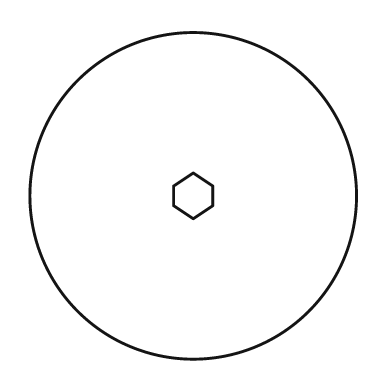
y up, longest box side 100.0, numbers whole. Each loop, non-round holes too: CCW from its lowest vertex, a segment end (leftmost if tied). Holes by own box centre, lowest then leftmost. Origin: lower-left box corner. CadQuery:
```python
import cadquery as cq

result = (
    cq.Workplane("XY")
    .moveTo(50.0, 50.0)
    .circle(50.0)
    .moveTo(50.0, 43.0)
    .lineTo(56.0, 47.0)
    .lineTo(56.0, 53.0)
    .lineTo(50.0, 57.0)
    .lineTo(44.0, 53.0)
    .lineTo(44.0, 47.0)
    .close()
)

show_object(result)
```